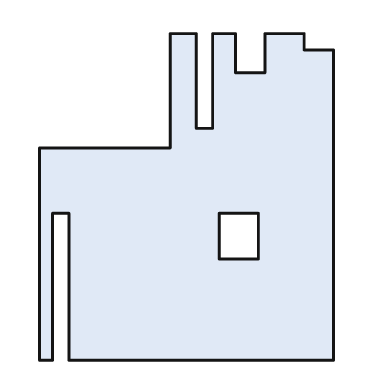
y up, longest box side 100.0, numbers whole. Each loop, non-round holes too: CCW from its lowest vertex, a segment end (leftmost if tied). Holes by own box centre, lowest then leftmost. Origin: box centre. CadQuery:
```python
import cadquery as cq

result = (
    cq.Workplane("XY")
    .moveTo(-45.0, -50.0)
    .lineTo(-41.0, -50.0)
    .lineTo(-41.0, -5.0)
    .lineTo(-36.0, -5.0)
    .lineTo(-36.0, -50.0)
    .lineTo(45.0, -50.0)
    .lineTo(45.0, 45.0)
    .lineTo(36.0, 45.0)
    .lineTo(36.0, 50.0)
    .lineTo(24.0, 50.0)
    .lineTo(24.0, 38.0)
    .lineTo(15.0, 38.0)
    .lineTo(15.0, 50.0)
    .lineTo(8.0, 50.0)
    .lineTo(8.0, 21.0)
    .lineTo(3.0, 21.0)
    .lineTo(3.0, 50.0)
    .lineTo(-5.0, 50.0)
    .lineTo(-5.0, 15.0)
    .lineTo(-45.0, 15.0)
    .close()
    .moveTo(10.0, -19.0)
    .lineTo(22.0, -19.0)
    .lineTo(22.0, -5.0)
    .lineTo(10.0, -5.0)
    .close()
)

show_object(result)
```